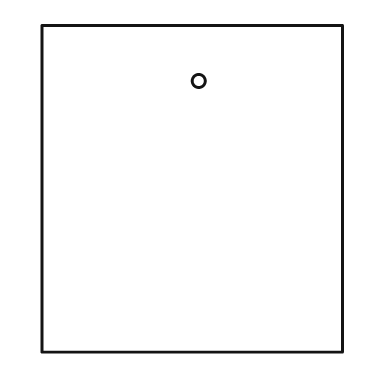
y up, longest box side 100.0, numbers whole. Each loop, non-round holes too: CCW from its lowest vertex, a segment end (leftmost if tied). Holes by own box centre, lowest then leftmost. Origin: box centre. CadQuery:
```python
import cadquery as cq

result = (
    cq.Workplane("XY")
    .moveTo(-46.0, -50.0)
    .lineTo(46.0, -50.0)
    .lineTo(46.0, 50.0)
    .lineTo(-46.0, 50.0)
    .close()
    .moveTo(2.0, 33.0)
    .circle(2.0)
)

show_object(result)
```